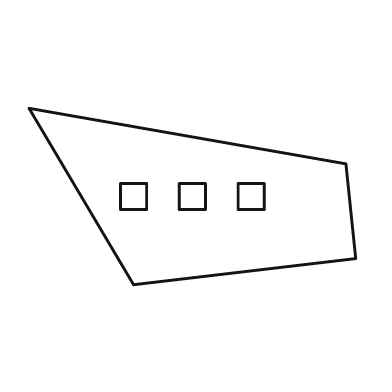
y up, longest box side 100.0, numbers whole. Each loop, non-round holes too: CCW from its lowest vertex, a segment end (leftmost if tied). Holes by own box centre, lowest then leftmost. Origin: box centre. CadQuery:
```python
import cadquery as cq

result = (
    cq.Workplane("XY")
    .moveTo(-18.0, -27.0)
    .lineTo(50.0, -19.0)
    .lineTo(47.0, 10.0)
    .lineTo(-50.0, 27.0)
    .close()
    .moveTo(-22.0, -4.0)
    .lineTo(-14.0, -4.0)
    .lineTo(-14.0, 4.0)
    .lineTo(-22.0, 4.0)
    .close()
    .moveTo(-4.0, -4.0)
    .lineTo(4.0, -4.0)
    .lineTo(4.0, 4.0)
    .lineTo(-4.0, 4.0)
    .close()
    .moveTo(14.0, -4.0)
    .lineTo(22.0, -4.0)
    .lineTo(22.0, 4.0)
    .lineTo(14.0, 4.0)
    .close()
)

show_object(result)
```